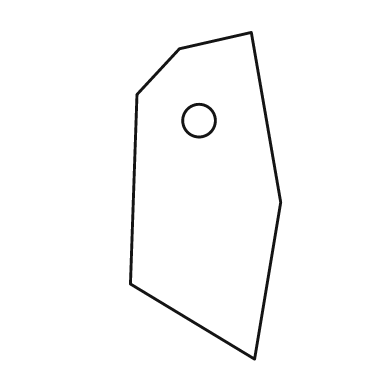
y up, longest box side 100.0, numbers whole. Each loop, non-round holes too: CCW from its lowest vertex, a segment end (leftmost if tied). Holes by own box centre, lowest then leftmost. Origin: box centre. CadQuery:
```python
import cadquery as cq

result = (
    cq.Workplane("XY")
    .moveTo(15.0, -50.0)
    .lineTo(23.0, -2.0)
    .lineTo(14.0, 50.0)
    .lineTo(-8.0, 45.0)
    .lineTo(-21.0, 31.0)
    .lineTo(-23.0, -27.0)
    .close()
    .moveTo(-2.0, 23.0)
    .circle(5.0)
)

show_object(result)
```